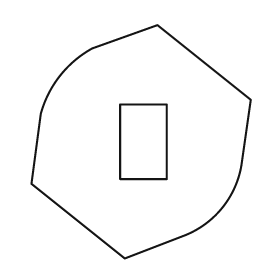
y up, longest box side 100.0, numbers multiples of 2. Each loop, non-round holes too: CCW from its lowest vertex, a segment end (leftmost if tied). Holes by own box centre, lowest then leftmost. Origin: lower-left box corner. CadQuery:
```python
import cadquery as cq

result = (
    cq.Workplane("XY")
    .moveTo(40.0, 0.0)
    .lineTo(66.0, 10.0)
    .threePointArc((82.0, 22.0), (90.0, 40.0))
    .lineTo(94.0, 68.0)
    .lineTo(54.0, 100.0)
    .lineTo(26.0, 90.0)
    .threePointArc((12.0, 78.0), (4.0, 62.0))
    .lineTo(0.0, 32.0)
    .close()
    .moveTo(38.0, 34.0)
    .lineTo(58.0, 34.0)
    .lineTo(58.0, 66.0)
    .lineTo(38.0, 66.0)
    .close()
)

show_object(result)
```